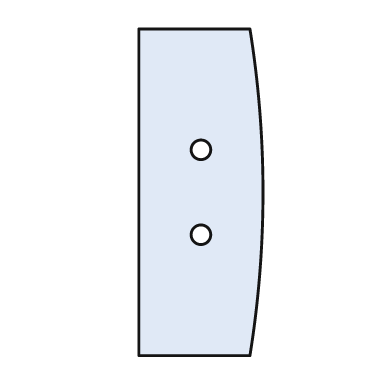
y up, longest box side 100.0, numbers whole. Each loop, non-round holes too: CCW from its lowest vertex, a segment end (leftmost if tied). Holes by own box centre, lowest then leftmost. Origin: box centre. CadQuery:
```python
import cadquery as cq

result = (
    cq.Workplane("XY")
    .moveTo(-19.0, -50.0)
    .lineTo(15.0, -50.0)
    .threePointArc((19.0, 0.0), (15.0, 50.0))
    .lineTo(-19.0, 50.0)
    .close()
    .moveTo(0.0, -13.0)
    .circle(3.0)
    .moveTo(0.0, 13.0)
    .circle(3.0)
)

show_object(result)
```